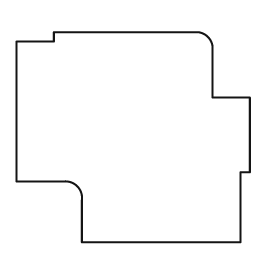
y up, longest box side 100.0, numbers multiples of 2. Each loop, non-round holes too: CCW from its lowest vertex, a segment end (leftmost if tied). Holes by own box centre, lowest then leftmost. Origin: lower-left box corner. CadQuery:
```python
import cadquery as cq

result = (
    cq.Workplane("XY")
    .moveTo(28.0, 0.0)
    .lineTo(96.0, 0.0)
    .lineTo(96.0, 30.0)
    .lineTo(100.0, 30.0)
    .lineTo(100.0, 62.0)
    .lineTo(84.0, 62.0)
    .lineTo(84.0, 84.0)
    .threePointArc((82.0, 88.0), (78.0, 90.0))
    .lineTo(16.0, 90.0)
    .lineTo(16.0, 86.0)
    .lineTo(0.0, 86.0)
    .lineTo(0.0, 26.0)
    .lineTo(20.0, 26.0)
    .threePointArc((26.0, 24.0), (28.0, 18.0))
    .close()
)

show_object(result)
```